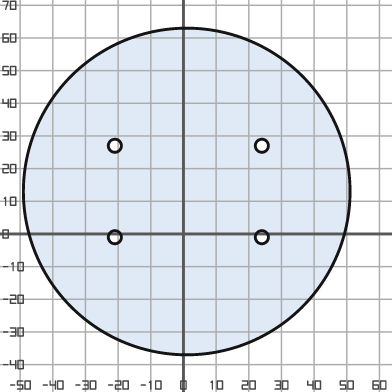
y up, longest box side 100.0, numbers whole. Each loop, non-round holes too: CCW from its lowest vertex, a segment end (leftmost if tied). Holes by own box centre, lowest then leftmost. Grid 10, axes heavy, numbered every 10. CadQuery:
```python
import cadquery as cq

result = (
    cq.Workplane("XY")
    .moveTo(1.0, 13.0)
    .circle(50.0)
    .moveTo(-21.0, -1.0)
    .circle(2.0)
    .moveTo(24.0, -1.0)
    .circle(2.0)
    .moveTo(-21.0, 27.0)
    .circle(2.0)
    .moveTo(24.0, 27.0)
    .circle(2.0)
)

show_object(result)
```